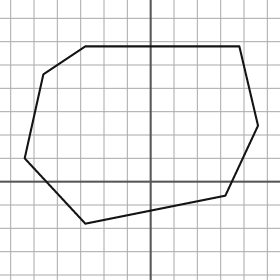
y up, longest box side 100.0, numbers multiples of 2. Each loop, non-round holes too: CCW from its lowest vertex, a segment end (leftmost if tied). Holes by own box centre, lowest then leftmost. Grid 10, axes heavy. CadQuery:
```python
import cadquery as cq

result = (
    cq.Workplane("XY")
    .moveTo(-28.0, -18.0)
    .lineTo(32.0, -6.0)
    .lineTo(46.0, 24.0)
    .lineTo(38.0, 58.0)
    .lineTo(-28.0, 58.0)
    .lineTo(-46.0, 46.0)
    .lineTo(-54.0, 10.0)
    .close()
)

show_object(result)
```